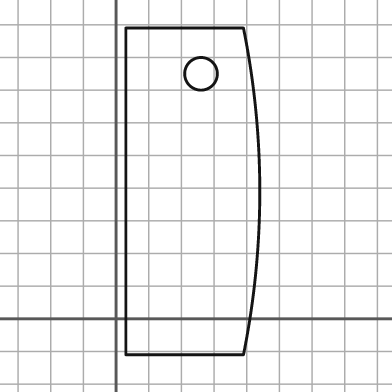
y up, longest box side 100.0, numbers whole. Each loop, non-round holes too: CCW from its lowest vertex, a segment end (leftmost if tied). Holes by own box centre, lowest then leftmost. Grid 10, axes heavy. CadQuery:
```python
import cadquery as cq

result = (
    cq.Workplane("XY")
    .moveTo(3.0, -11.0)
    .lineTo(39.0, -11.0)
    .threePointArc((44.0, 39.0), (39.0, 89.0))
    .lineTo(3.0, 89.0)
    .close()
    .moveTo(26.0, 75.0)
    .circle(5.0)
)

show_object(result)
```